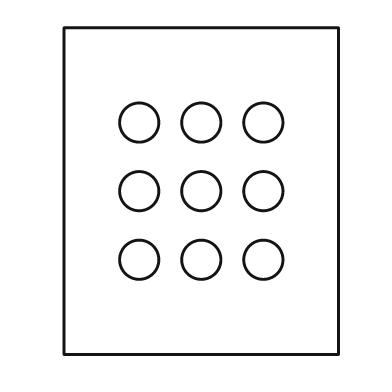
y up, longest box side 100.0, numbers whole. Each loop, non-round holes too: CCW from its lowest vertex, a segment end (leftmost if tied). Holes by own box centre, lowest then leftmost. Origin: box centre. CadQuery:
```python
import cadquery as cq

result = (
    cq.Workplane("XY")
    .moveTo(-42.0, -50.0)
    .lineTo(42.0, -50.0)
    .lineTo(42.0, 50.0)
    .lineTo(-42.0, 50.0)
    .close()
    .moveTo(-19.0, -21.0)
    .circle(6.0)
    .moveTo(0.0, -21.0)
    .circle(6.0)
    .moveTo(19.0, -21.0)
    .circle(6.0)
    .moveTo(-19.0, 0.0)
    .circle(6.0)
    .moveTo(0.0, 0.0)
    .circle(6.0)
    .moveTo(19.0, 0.0)
    .circle(6.0)
    .moveTo(-19.0, 21.0)
    .circle(6.0)
    .moveTo(0.0, 21.0)
    .circle(6.0)
    .moveTo(19.0, 21.0)
    .circle(6.0)
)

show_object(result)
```